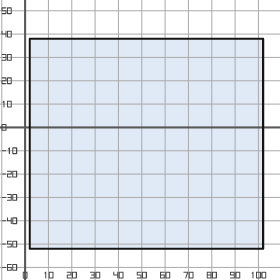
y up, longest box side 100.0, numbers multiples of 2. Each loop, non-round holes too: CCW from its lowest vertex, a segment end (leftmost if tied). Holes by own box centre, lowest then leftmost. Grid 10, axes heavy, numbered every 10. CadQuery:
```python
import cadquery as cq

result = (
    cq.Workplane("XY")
    .moveTo(2.0, -52.0)
    .lineTo(102.0, -52.0)
    .lineTo(102.0, 38.0)
    .lineTo(2.0, 38.0)
    .close()
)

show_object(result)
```